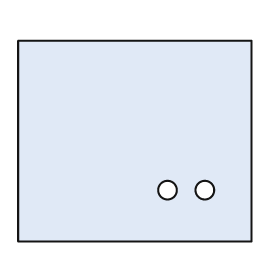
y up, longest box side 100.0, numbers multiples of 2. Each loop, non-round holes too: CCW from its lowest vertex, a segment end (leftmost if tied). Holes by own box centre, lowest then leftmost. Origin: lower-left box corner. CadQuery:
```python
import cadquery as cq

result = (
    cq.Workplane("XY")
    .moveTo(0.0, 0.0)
    .lineTo(100.0, 0.0)
    .lineTo(100.0, 86.0)
    .lineTo(0.0, 86.0)
    .close()
    .moveTo(64.0, 22.0)
    .circle(4.0)
    .moveTo(80.0, 22.0)
    .circle(4.0)
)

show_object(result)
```